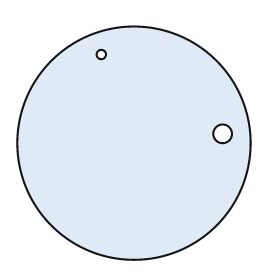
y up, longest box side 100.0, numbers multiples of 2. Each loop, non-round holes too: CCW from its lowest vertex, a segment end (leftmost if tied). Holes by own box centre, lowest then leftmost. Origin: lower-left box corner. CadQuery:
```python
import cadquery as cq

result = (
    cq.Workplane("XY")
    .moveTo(50.0, 50.0)
    .circle(50.0)
    .moveTo(88.0, 54.0)
    .circle(4.0)
    .moveTo(36.0, 88.0)
    .circle(2.0)
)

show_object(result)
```